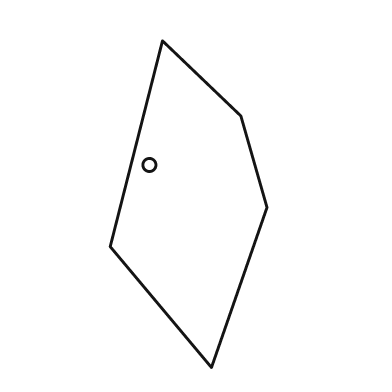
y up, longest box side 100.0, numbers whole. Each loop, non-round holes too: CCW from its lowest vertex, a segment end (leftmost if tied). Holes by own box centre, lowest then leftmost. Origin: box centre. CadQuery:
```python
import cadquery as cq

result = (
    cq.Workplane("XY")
    .moveTo(7.0, -50.0)
    .lineTo(24.0, -1.0)
    .lineTo(16.0, 27.0)
    .lineTo(-8.0, 50.0)
    .lineTo(-24.0, -13.0)
    .close()
    .moveTo(-12.0, 12.0)
    .circle(2.0)
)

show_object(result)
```